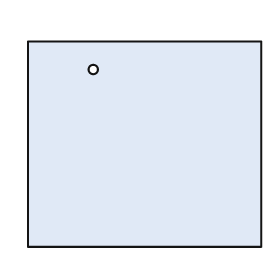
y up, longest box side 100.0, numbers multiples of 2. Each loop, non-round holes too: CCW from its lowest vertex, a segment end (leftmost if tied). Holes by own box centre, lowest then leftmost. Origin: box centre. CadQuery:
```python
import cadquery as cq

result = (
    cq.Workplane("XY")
    .moveTo(-50.0, -44.0)
    .lineTo(50.0, -44.0)
    .lineTo(50.0, 44.0)
    .lineTo(-50.0, 44.0)
    .close()
    .moveTo(-22.0, 32.0)
    .circle(2.0)
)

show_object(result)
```